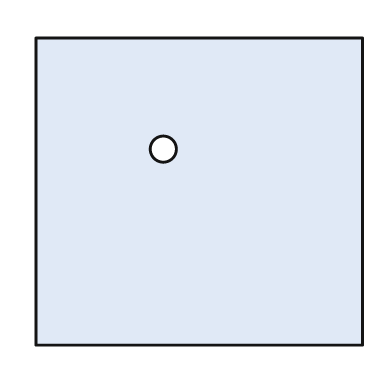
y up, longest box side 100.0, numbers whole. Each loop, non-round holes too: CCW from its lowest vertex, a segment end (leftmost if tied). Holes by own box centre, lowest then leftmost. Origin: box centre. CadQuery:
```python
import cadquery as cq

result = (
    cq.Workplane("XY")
    .moveTo(-50.0, -47.0)
    .lineTo(50.0, -47.0)
    .lineTo(50.0, 47.0)
    .lineTo(-50.0, 47.0)
    .close()
    .moveTo(-11.0, 13.0)
    .circle(4.0)
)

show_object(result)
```